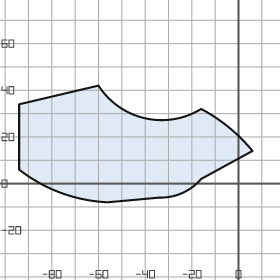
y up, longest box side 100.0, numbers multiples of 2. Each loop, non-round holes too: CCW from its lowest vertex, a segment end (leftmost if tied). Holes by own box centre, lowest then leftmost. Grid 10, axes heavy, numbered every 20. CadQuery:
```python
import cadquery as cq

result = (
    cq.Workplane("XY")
    .moveTo(-56.0, -8.0)
    .lineTo(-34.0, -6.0)
    .threePointArc((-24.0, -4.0), (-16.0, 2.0))
    .lineTo(6.0, 14.0)
    .threePointArc((-4.0, 24.0), (-16.0, 32.0))
    .threePointArc((-40.0, 28.0), (-60.0, 42.0))
    .lineTo(-94.0, 34.0)
    .lineTo(-94.0, 6.0)
    .threePointArc((-76.0, -4.0), (-56.0, -8.0))
    .close()
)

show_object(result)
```